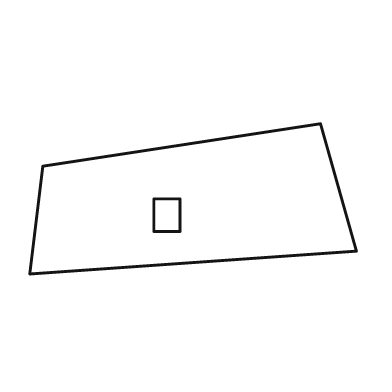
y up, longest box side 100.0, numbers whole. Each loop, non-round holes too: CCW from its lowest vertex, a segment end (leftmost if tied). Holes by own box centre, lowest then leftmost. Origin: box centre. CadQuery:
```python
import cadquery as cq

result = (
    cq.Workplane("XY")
    .moveTo(-50.0, -23.0)
    .lineTo(50.0, -16.0)
    .lineTo(39.0, 23.0)
    .lineTo(-46.0, 10.0)
    .close()
    .moveTo(-12.0, -10.0)
    .lineTo(-4.0, -10.0)
    .lineTo(-4.0, 0.0)
    .lineTo(-12.0, 0.0)
    .close()
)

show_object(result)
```